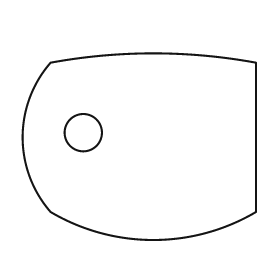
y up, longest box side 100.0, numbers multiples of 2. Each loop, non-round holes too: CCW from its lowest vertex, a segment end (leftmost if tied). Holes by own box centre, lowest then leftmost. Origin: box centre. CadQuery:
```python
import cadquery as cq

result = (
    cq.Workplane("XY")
    .moveTo(-38.0, -28.0)
    .threePointArc((6.0, -40.0), (50.0, -28.0))
    .lineTo(50.0, 36.0)
    .threePointArc((6.0, 40.0), (-38.0, 36.0))
    .threePointArc((-50.0, 4.0), (-38.0, -28.0))
    .close()
    .moveTo(-24.0, 6.0)
    .circle(8.0)
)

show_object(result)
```